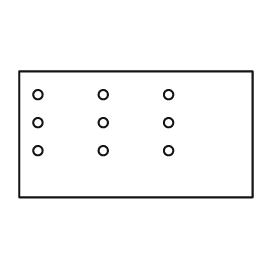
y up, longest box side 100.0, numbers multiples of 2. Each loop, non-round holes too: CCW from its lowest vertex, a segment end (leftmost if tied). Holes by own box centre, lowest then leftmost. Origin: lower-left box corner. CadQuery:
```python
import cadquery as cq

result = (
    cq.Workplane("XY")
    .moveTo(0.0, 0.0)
    .lineTo(100.0, 0.0)
    .lineTo(100.0, 54.0)
    .lineTo(0.0, 54.0)
    .close()
    .moveTo(8.0, 20.0)
    .circle(2.0)
    .moveTo(36.0, 20.0)
    .circle(2.0)
    .moveTo(64.0, 20.0)
    .circle(2.0)
    .moveTo(8.0, 32.0)
    .circle(2.0)
    .moveTo(36.0, 32.0)
    .circle(2.0)
    .moveTo(64.0, 32.0)
    .circle(2.0)
    .moveTo(8.0, 44.0)
    .circle(2.0)
    .moveTo(36.0, 44.0)
    .circle(2.0)
    .moveTo(64.0, 44.0)
    .circle(2.0)
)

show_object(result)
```